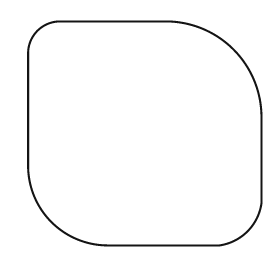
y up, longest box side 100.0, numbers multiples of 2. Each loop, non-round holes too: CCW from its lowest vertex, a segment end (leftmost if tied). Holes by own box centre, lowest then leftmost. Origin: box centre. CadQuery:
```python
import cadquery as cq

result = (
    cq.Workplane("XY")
    .moveTo(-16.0, -48.0)
    .lineTo(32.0, -48.0)
    .threePointArc((44.0, -42.0), (50.0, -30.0))
    .lineTo(50.0, 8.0)
    .threePointArc((38.0, 36.0), (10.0, 48.0))
    .lineTo(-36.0, 48.0)
    .threePointArc((-46.0, 44.0), (-50.0, 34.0))
    .lineTo(-50.0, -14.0)
    .threePointArc((-40.0, -38.0), (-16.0, -48.0))
    .close()
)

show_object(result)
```